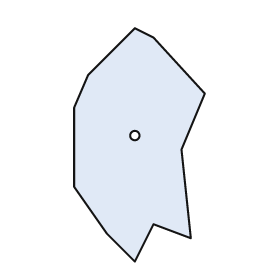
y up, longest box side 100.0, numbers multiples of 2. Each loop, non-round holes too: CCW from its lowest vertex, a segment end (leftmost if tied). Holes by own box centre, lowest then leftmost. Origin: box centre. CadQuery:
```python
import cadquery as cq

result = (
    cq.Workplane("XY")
    .moveTo(-2.0, -50.0)
    .lineTo(6.0, -34.0)
    .lineTo(22.0, -40.0)
    .lineTo(18.0, -2.0)
    .lineTo(28.0, 22.0)
    .lineTo(6.0, 46.0)
    .lineTo(-2.0, 50.0)
    .lineTo(-22.0, 30.0)
    .lineTo(-28.0, 16.0)
    .lineTo(-28.0, -18.0)
    .lineTo(-14.0, -38.0)
    .close()
    .moveTo(-2.0, 4.0)
    .circle(2.0)
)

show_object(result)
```